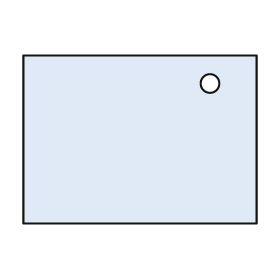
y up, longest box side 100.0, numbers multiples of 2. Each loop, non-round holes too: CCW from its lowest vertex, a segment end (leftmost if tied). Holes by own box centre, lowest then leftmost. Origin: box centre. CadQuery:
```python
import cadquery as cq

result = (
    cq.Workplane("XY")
    .moveTo(-50.0, -36.0)
    .lineTo(50.0, -36.0)
    .lineTo(50.0, 36.0)
    .lineTo(-50.0, 36.0)
    .close()
    .moveTo(30.0, 24.0)
    .circle(4.0)
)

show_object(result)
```